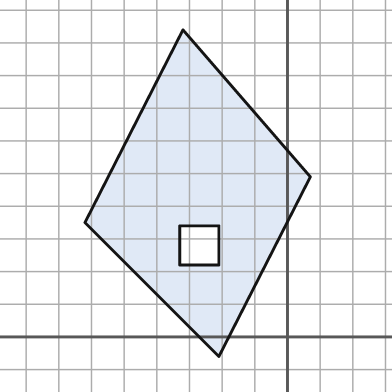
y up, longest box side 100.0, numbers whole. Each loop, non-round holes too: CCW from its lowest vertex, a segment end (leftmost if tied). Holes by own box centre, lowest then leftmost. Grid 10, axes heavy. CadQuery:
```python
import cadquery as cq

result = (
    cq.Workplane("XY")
    .moveTo(-21.0, -6.0)
    .lineTo(7.0, 49.0)
    .lineTo(-32.0, 94.0)
    .lineTo(-62.0, 35.0)
    .close()
    .moveTo(-33.0, 22.0)
    .lineTo(-21.0, 22.0)
    .lineTo(-21.0, 34.0)
    .lineTo(-33.0, 34.0)
    .close()
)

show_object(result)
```